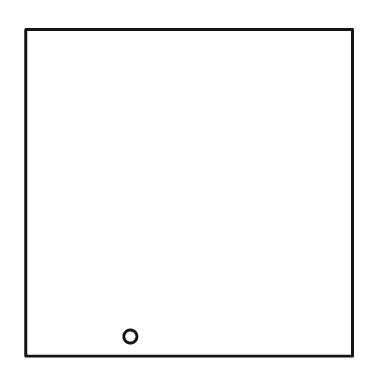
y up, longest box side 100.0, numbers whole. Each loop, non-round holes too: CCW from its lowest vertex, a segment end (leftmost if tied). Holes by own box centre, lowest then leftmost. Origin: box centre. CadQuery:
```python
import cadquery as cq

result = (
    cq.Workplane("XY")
    .moveTo(-50.0, -50.0)
    .lineTo(50.0, -50.0)
    .lineTo(50.0, 50.0)
    .lineTo(-50.0, 50.0)
    .close()
    .moveTo(-18.0, -44.0)
    .circle(2.0)
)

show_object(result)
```